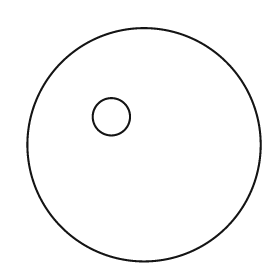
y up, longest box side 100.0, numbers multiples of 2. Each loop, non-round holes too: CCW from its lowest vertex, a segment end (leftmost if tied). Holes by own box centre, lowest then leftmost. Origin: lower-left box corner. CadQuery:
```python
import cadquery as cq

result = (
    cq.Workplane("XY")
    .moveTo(50.0, 50.0)
    .circle(50.0)
    .moveTo(36.0, 62.0)
    .circle(8.0)
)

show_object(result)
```